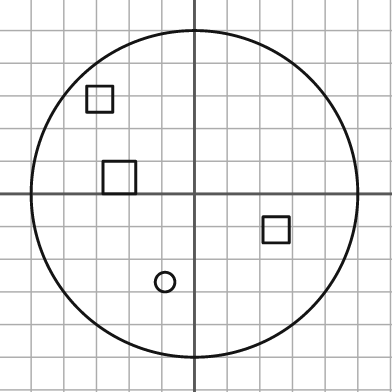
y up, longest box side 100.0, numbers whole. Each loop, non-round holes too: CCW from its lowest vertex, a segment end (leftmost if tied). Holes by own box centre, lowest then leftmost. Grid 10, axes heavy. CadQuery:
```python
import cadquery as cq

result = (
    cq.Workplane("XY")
    .moveTo(0.0, 0.0)
    .circle(50.0)
    .moveTo(-9.0, -27.0)
    .circle(3.0)
    .moveTo(21.0, -15.0)
    .lineTo(29.0, -15.0)
    .lineTo(29.0, -7.0)
    .lineTo(21.0, -7.0)
    .close()
    .moveTo(-28.0, 0.0)
    .lineTo(-18.0, 0.0)
    .lineTo(-18.0, 10.0)
    .lineTo(-28.0, 10.0)
    .close()
    .moveTo(-33.0, 25.0)
    .lineTo(-25.0, 25.0)
    .lineTo(-25.0, 33.0)
    .lineTo(-33.0, 33.0)
    .close()
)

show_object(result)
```